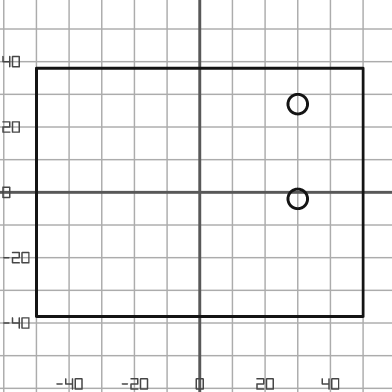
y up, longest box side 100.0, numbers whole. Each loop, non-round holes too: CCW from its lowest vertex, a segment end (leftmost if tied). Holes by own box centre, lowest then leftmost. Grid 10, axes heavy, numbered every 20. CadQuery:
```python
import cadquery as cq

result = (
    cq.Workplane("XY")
    .moveTo(-50.0, -38.0)
    .lineTo(50.0, -38.0)
    .lineTo(50.0, 38.0)
    .lineTo(-50.0, 38.0)
    .close()
    .moveTo(30.0, -2.0)
    .circle(3.0)
    .moveTo(30.0, 27.0)
    .circle(3.0)
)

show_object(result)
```